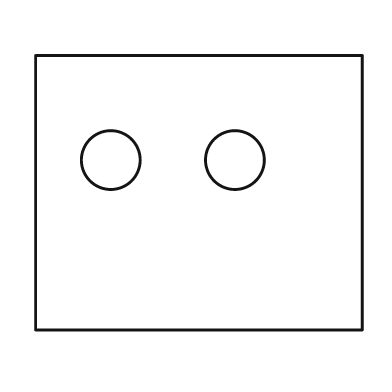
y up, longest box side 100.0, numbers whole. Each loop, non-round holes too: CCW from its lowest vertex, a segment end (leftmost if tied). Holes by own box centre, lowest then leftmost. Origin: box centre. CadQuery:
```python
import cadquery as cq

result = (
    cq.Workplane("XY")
    .moveTo(-50.0, -42.0)
    .lineTo(50.0, -42.0)
    .lineTo(50.0, 42.0)
    .lineTo(-50.0, 42.0)
    .close()
    .moveTo(-27.0, 10.0)
    .circle(9.0)
    .moveTo(11.0, 10.0)
    .circle(9.0)
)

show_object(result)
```